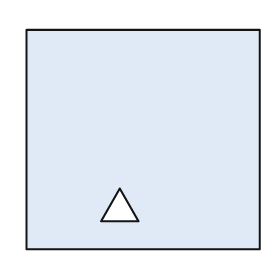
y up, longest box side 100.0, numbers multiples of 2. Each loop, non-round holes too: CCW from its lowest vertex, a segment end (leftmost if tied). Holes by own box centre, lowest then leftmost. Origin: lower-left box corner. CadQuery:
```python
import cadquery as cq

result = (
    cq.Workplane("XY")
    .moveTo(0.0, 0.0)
    .lineTo(100.0, 0.0)
    .lineTo(100.0, 94.0)
    .lineTo(0.0, 94.0)
    .close()
    .moveTo(32.0, 12.0)
    .lineTo(48.0, 12.0)
    .lineTo(40.0, 26.0)
    .close()
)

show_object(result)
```